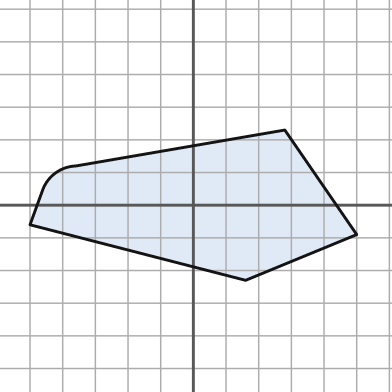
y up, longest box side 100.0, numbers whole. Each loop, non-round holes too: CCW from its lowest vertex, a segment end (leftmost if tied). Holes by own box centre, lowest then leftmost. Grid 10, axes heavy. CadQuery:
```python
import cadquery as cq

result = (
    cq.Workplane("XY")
    .moveTo(16.0, -23.0)
    .lineTo(50.0, -9.0)
    .lineTo(28.0, 23.0)
    .lineTo(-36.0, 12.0)
    .threePointArc((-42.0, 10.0), (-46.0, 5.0))
    .lineTo(-50.0, -6.0)
    .close()
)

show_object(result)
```